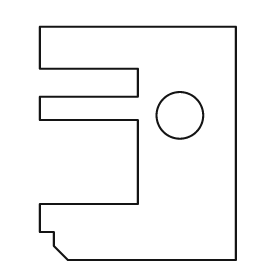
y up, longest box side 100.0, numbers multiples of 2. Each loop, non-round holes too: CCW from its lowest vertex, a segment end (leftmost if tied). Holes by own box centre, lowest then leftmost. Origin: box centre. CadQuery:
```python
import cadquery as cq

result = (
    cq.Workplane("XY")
    .moveTo(-30.0, -50.0)
    .lineTo(42.0, -50.0)
    .lineTo(42.0, 50.0)
    .lineTo(-42.0, 50.0)
    .lineTo(-42.0, 32.0)
    .lineTo(0.0, 32.0)
    .lineTo(0.0, 20.0)
    .lineTo(-42.0, 20.0)
    .lineTo(-42.0, 10.0)
    .lineTo(0.0, 10.0)
    .lineTo(0.0, -26.0)
    .lineTo(-42.0, -26.0)
    .lineTo(-42.0, -38.0)
    .lineTo(-36.0, -38.0)
    .lineTo(-36.0, -44.0)
    .close()
    .moveTo(18.0, 12.0)
    .circle(10.0)
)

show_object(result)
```